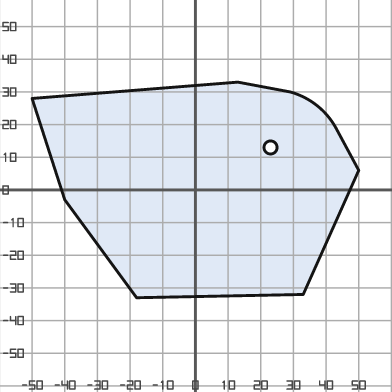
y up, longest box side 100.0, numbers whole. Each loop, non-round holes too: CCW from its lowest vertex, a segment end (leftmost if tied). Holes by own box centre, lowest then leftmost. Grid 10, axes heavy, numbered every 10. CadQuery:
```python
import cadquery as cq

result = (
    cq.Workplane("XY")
    .moveTo(-18.0, -33.0)
    .lineTo(33.0, -32.0)
    .lineTo(50.0, 6.0)
    .lineTo(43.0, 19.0)
    .threePointArc((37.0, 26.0), (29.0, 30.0))
    .lineTo(13.0, 33.0)
    .lineTo(-50.0, 28.0)
    .lineTo(-40.0, -3.0)
    .close()
    .moveTo(23.0, 13.0)
    .circle(2.0)
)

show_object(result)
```